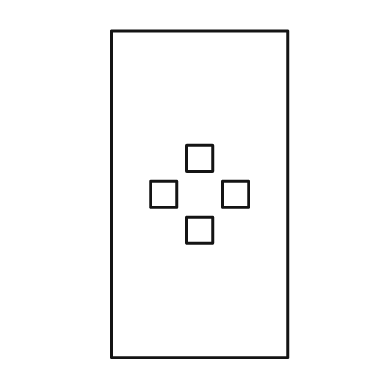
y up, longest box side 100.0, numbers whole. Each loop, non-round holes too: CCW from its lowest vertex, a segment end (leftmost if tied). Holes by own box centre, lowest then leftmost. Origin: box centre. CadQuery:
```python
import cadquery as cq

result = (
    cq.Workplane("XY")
    .moveTo(-27.0, -50.0)
    .lineTo(27.0, -50.0)
    .lineTo(27.0, 50.0)
    .lineTo(-27.0, 50.0)
    .close()
    .moveTo(-4.0, -15.0)
    .lineTo(4.0, -15.0)
    .lineTo(4.0, -7.0)
    .lineTo(-4.0, -7.0)
    .close()
    .moveTo(-15.0, -4.0)
    .lineTo(-7.0, -4.0)
    .lineTo(-7.0, 4.0)
    .lineTo(-15.0, 4.0)
    .close()
    .moveTo(7.0, -4.0)
    .lineTo(15.0, -4.0)
    .lineTo(15.0, 4.0)
    .lineTo(7.0, 4.0)
    .close()
    .moveTo(-4.0, 7.0)
    .lineTo(4.0, 7.0)
    .lineTo(4.0, 15.0)
    .lineTo(-4.0, 15.0)
    .close()
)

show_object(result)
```